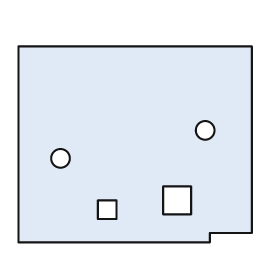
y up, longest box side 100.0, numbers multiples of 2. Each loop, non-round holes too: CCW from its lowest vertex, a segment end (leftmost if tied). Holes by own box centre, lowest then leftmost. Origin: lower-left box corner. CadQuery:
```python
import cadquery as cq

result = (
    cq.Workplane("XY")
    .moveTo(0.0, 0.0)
    .lineTo(82.0, 0.0)
    .lineTo(82.0, 4.0)
    .lineTo(100.0, 4.0)
    .lineTo(100.0, 84.0)
    .lineTo(0.0, 84.0)
    .close()
    .moveTo(34.0, 10.0)
    .lineTo(42.0, 10.0)
    .lineTo(42.0, 18.0)
    .lineTo(34.0, 18.0)
    .close()
    .moveTo(62.0, 12.0)
    .lineTo(74.0, 12.0)
    .lineTo(74.0, 24.0)
    .lineTo(62.0, 24.0)
    .close()
    .moveTo(18.0, 36.0)
    .circle(4.0)
    .moveTo(80.0, 48.0)
    .circle(4.0)
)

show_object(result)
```